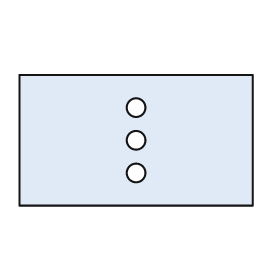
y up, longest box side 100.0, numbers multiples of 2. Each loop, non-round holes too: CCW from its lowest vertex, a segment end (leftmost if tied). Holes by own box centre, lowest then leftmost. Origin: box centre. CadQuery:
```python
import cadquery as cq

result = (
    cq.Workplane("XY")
    .moveTo(-50.0, -28.0)
    .lineTo(50.0, -28.0)
    .lineTo(50.0, 28.0)
    .lineTo(-50.0, 28.0)
    .close()
    .moveTo(0.0, -14.0)
    .circle(4.0)
    .moveTo(0.0, 0.0)
    .circle(4.0)
    .moveTo(0.0, 14.0)
    .circle(4.0)
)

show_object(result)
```